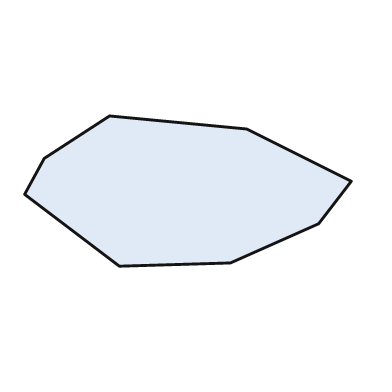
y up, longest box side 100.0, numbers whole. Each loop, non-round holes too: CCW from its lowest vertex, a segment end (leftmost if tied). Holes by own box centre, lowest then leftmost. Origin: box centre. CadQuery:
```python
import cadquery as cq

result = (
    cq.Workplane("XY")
    .moveTo(-21.0, -23.0)
    .lineTo(13.0, -22.0)
    .lineTo(40.0, -10.0)
    .lineTo(50.0, 3.0)
    .lineTo(18.0, 19.0)
    .lineTo(-24.0, 23.0)
    .lineTo(-44.0, 10.0)
    .lineTo(-50.0, -1.0)
    .close()
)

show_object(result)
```